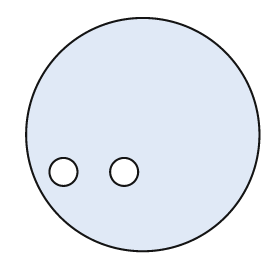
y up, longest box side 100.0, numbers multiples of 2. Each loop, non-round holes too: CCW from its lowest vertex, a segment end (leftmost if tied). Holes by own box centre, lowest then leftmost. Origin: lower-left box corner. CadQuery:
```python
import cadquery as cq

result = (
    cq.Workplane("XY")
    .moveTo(50.0, 50.0)
    .circle(50.0)
    .moveTo(16.0, 34.0)
    .circle(6.0)
    .moveTo(42.0, 34.0)
    .circle(6.0)
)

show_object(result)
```